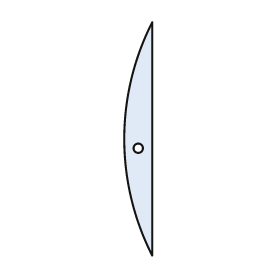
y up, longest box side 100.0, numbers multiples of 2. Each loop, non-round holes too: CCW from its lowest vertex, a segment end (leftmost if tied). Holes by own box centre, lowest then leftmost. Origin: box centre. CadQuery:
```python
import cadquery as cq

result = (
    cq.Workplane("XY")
    .moveTo(6.0, -50.0)
    .lineTo(6.0, 50.0)
    .threePointArc((-6.0, 0.0), (6.0, -50.0))
    .close()
    .moveTo(0.0, -4.0)
    .circle(2.0)
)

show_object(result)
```